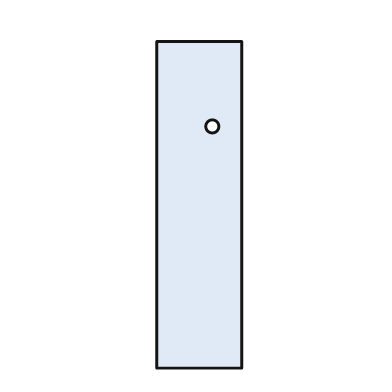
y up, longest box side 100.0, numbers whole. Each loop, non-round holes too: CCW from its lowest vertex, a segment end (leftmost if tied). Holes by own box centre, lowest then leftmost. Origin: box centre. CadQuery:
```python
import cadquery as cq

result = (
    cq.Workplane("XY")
    .moveTo(-13.0, -50.0)
    .lineTo(13.0, -50.0)
    .lineTo(13.0, 50.0)
    .lineTo(-13.0, 50.0)
    .close()
    .moveTo(4.0, 24.0)
    .circle(2.0)
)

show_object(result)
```